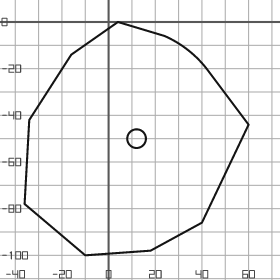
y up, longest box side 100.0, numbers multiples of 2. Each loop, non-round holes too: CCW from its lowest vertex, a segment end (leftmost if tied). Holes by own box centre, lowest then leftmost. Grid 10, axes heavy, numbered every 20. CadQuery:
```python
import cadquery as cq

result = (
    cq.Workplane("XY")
    .moveTo(-10.0, -100.0)
    .lineTo(18.0, -98.0)
    .lineTo(40.0, -86.0)
    .lineTo(60.0, -44.0)
    .lineTo(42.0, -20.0)
    .threePointArc((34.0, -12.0), (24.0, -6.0))
    .lineTo(4.0, 0.0)
    .lineTo(-16.0, -14.0)
    .lineTo(-34.0, -42.0)
    .lineTo(-36.0, -78.0)
    .close()
    .moveTo(12.0, -50.0)
    .circle(4.0)
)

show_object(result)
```